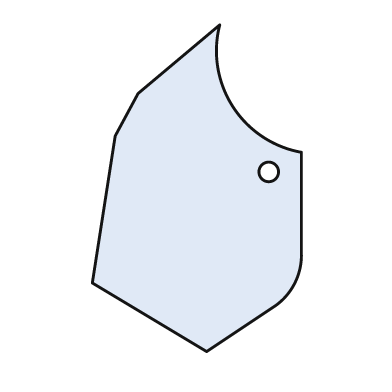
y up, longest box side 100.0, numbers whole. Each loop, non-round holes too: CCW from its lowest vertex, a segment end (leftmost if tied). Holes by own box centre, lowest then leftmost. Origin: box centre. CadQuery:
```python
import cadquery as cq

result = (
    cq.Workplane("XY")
    .moveTo(3.0, -50.0)
    .lineTo(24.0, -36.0)
    .threePointArc((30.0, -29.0), (32.0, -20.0))
    .lineTo(32.0, 11.0)
    .threePointArc((11.0, 25.0), (7.0, 50.0))
    .lineTo(-18.0, 29.0)
    .lineTo(-25.0, 16.0)
    .lineTo(-32.0, -29.0)
    .close()
    .moveTo(22.0, 5.0)
    .circle(3.0)
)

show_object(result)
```